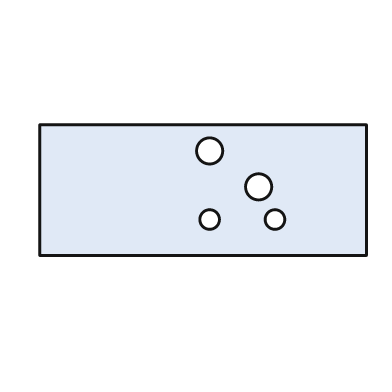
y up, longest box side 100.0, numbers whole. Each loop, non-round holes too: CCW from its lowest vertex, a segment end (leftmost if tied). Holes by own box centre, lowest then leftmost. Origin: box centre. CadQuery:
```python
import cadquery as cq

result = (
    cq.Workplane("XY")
    .moveTo(-50.0, -20.0)
    .lineTo(50.0, -20.0)
    .lineTo(50.0, 20.0)
    .lineTo(-50.0, 20.0)
    .close()
    .moveTo(2.0, -9.0)
    .circle(3.0)
    .moveTo(22.0, -9.0)
    .circle(3.0)
    .moveTo(17.0, 1.0)
    .circle(4.0)
    .moveTo(2.0, 12.0)
    .circle(4.0)
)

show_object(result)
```